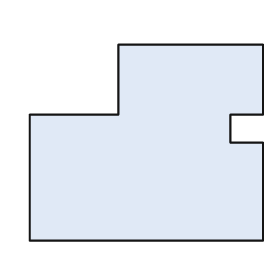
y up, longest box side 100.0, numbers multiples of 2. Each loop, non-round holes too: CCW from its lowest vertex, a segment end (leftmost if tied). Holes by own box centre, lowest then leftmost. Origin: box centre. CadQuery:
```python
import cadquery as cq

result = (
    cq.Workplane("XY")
    .moveTo(-50.0, -42.0)
    .lineTo(50.0, -42.0)
    .lineTo(50.0, 0.0)
    .lineTo(36.0, 0.0)
    .lineTo(36.0, 12.0)
    .lineTo(50.0, 12.0)
    .lineTo(50.0, 42.0)
    .lineTo(-12.0, 42.0)
    .lineTo(-12.0, 12.0)
    .lineTo(-50.0, 12.0)
    .close()
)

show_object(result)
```